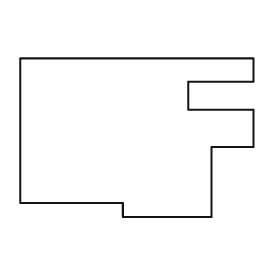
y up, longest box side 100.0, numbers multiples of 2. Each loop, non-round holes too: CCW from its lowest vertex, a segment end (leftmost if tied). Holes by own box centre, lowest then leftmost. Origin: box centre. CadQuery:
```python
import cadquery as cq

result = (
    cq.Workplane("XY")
    .moveTo(-6.0, -34.0)
    .lineTo(32.0, -34.0)
    .lineTo(32.0, -4.0)
    .lineTo(50.0, -4.0)
    .lineTo(50.0, 12.0)
    .lineTo(22.0, 12.0)
    .lineTo(22.0, 24.0)
    .lineTo(50.0, 24.0)
    .lineTo(50.0, 34.0)
    .lineTo(-50.0, 34.0)
    .lineTo(-50.0, -28.0)
    .lineTo(-6.0, -28.0)
    .close()
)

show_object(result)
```